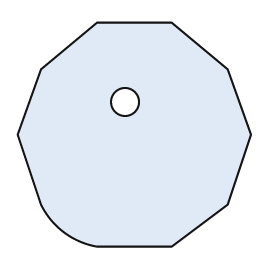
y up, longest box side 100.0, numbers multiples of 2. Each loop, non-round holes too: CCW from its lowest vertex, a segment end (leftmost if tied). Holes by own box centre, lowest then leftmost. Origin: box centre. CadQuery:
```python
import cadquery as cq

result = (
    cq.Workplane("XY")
    .moveTo(-16.0, -48.0)
    .lineTo(16.0, -48.0)
    .lineTo(40.0, -30.0)
    .lineTo(50.0, 0.0)
    .lineTo(40.0, 28.0)
    .lineTo(16.0, 48.0)
    .lineTo(-16.0, 48.0)
    .lineTo(-40.0, 28.0)
    .lineTo(-50.0, 0.0)
    .lineTo(-40.0, -30.0)
    .threePointArc((-30.0, -42.0), (-16.0, -48.0))
    .close()
    .moveTo(-4.0, 14.0)
    .circle(6.0)
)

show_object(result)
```